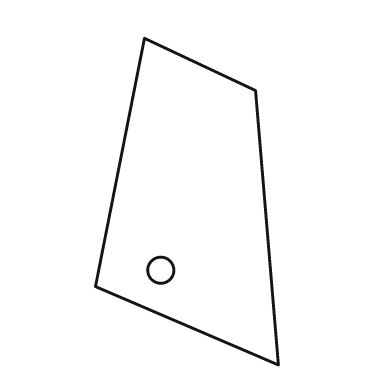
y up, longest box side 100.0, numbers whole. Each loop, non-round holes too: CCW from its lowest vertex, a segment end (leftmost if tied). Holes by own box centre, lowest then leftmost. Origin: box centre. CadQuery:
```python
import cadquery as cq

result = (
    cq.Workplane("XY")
    .moveTo(28.0, -50.0)
    .lineTo(21.0, 34.0)
    .lineTo(-13.0, 50.0)
    .lineTo(-28.0, -26.0)
    .close()
    .moveTo(-8.0, -21.0)
    .circle(4.0)
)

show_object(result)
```